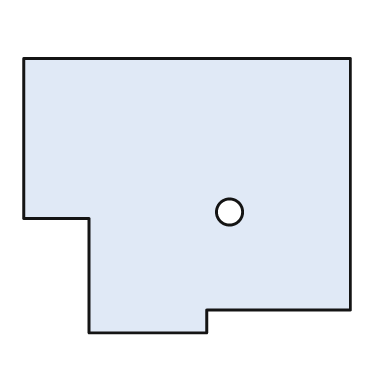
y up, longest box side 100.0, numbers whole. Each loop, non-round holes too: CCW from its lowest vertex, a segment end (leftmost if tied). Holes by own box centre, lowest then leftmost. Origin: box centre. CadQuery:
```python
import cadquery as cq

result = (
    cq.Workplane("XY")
    .moveTo(-30.0, -42.0)
    .lineTo(6.0, -42.0)
    .lineTo(6.0, -35.0)
    .lineTo(50.0, -35.0)
    .lineTo(50.0, 42.0)
    .lineTo(-50.0, 42.0)
    .lineTo(-50.0, -7.0)
    .lineTo(-30.0, -7.0)
    .close()
    .moveTo(13.0, -5.0)
    .circle(4.0)
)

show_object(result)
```